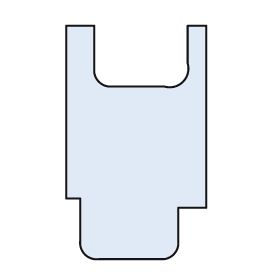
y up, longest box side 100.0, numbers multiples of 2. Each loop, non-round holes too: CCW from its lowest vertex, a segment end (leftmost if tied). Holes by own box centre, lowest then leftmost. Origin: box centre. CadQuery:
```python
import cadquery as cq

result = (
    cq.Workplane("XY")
    .moveTo(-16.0, -50.0)
    .lineTo(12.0, -50.0)
    .threePointArc((16.0, -48.0), (18.0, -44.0))
    .lineTo(18.0, -28.0)
    .lineTo(30.0, -28.0)
    .lineTo(30.0, 50.0)
    .lineTo(22.0, 50.0)
    .lineTo(22.0, 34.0)
    .threePointArc((20.0, 26.0), (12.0, 24.0))
    .lineTo(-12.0, 24.0)
    .threePointArc((-16.0, 26.0), (-18.0, 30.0))
    .lineTo(-18.0, 50.0)
    .lineTo(-30.0, 50.0)
    .lineTo(-30.0, -24.0)
    .lineTo(-24.0, -24.0)
    .lineTo(-24.0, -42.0)
    .threePointArc((-22.0, -48.0), (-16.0, -50.0))
    .close()
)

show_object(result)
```